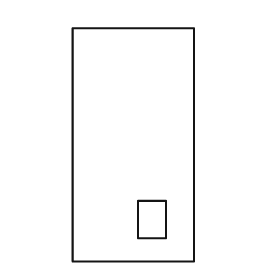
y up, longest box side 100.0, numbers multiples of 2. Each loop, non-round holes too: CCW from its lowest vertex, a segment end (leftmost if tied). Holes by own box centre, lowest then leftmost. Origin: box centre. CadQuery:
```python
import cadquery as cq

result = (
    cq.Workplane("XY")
    .moveTo(-26.0, -50.0)
    .lineTo(26.0, -50.0)
    .lineTo(26.0, 50.0)
    .lineTo(-26.0, 50.0)
    .close()
    .moveTo(2.0, -40.0)
    .lineTo(14.0, -40.0)
    .lineTo(14.0, -24.0)
    .lineTo(2.0, -24.0)
    .close()
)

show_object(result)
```